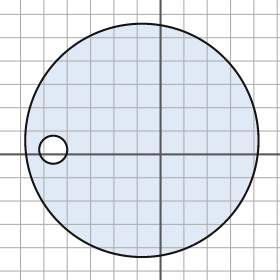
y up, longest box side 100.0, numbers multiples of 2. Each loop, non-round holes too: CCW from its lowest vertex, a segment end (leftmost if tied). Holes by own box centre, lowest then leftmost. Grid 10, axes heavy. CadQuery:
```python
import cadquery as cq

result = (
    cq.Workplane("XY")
    .moveTo(-8.0, 6.0)
    .circle(50.0)
    .moveTo(-46.0, 2.0)
    .circle(6.0)
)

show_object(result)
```